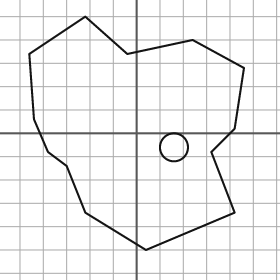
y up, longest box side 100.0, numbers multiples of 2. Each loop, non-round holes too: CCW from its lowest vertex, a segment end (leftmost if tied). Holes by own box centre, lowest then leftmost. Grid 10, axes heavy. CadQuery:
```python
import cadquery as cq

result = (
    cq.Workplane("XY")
    .moveTo(4.0, -50.0)
    .lineTo(42.0, -34.0)
    .lineTo(32.0, -8.0)
    .lineTo(42.0, 2.0)
    .lineTo(46.0, 28.0)
    .lineTo(24.0, 40.0)
    .lineTo(-4.0, 34.0)
    .lineTo(-22.0, 50.0)
    .lineTo(-46.0, 34.0)
    .lineTo(-44.0, 6.0)
    .lineTo(-38.0, -8.0)
    .lineTo(-30.0, -14.0)
    .lineTo(-22.0, -34.0)
    .close()
    .moveTo(16.0, -6.0)
    .circle(6.0)
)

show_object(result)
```